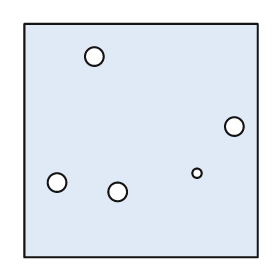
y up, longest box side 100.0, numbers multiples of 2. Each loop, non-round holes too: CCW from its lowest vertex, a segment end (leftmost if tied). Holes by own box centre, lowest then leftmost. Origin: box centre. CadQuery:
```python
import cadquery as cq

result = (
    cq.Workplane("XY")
    .moveTo(-50.0, -50.0)
    .lineTo(50.0, -50.0)
    .lineTo(50.0, 50.0)
    .lineTo(-50.0, 50.0)
    .close()
    .moveTo(-10.0, -22.0)
    .circle(4.0)
    .moveTo(-36.0, -18.0)
    .circle(4.0)
    .moveTo(24.0, -14.0)
    .circle(2.0)
    .moveTo(40.0, 6.0)
    .circle(4.0)
    .moveTo(-20.0, 36.0)
    .circle(4.0)
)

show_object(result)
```